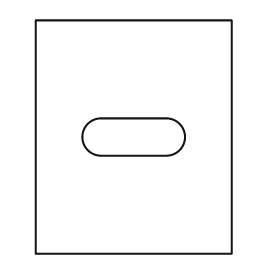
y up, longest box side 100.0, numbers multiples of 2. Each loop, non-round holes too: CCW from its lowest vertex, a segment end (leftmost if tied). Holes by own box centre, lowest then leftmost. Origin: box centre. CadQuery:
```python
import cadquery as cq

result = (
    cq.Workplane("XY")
    .moveTo(-42.0, -50.0)
    .lineTo(42.0, -50.0)
    .lineTo(42.0, 50.0)
    .lineTo(-42.0, 50.0)
    .close()
    .moveTo(-14.0, -8.0)
    .lineTo(14.0, -8.0)
    .threePointArc((22.0, 0.0), (14.0, 8.0))
    .lineTo(-14.0, 8.0)
    .threePointArc((-22.0, 0.0), (-14.0, -8.0))
    .close()
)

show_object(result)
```